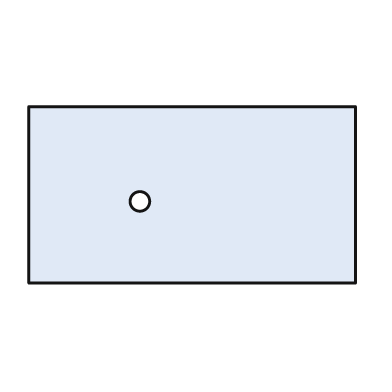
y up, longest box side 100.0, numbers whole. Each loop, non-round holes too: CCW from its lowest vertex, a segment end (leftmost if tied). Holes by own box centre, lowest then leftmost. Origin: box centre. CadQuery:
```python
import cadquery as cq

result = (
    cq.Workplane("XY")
    .moveTo(-50.0, -27.0)
    .lineTo(50.0, -27.0)
    .lineTo(50.0, 27.0)
    .lineTo(-50.0, 27.0)
    .close()
    .moveTo(-16.0, -2.0)
    .circle(3.0)
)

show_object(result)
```